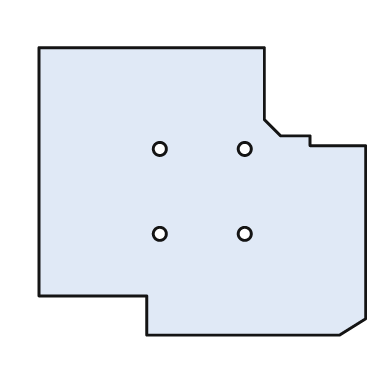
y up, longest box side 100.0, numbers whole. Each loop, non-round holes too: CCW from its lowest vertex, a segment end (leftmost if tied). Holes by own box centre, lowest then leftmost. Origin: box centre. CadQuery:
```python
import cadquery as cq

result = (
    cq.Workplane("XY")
    .moveTo(-17.0, -44.0)
    .lineTo(42.0, -44.0)
    .lineTo(50.0, -39.0)
    .lineTo(50.0, 14.0)
    .lineTo(33.0, 14.0)
    .lineTo(33.0, 17.0)
    .lineTo(24.0, 17.0)
    .lineTo(19.0, 22.0)
    .lineTo(19.0, 44.0)
    .lineTo(-50.0, 44.0)
    .lineTo(-50.0, -32.0)
    .lineTo(-17.0, -32.0)
    .close()
    .moveTo(-13.0, -13.0)
    .circle(2.0)
    .moveTo(13.0, -13.0)
    .circle(2.0)
    .moveTo(-13.0, 13.0)
    .circle(2.0)
    .moveTo(13.0, 13.0)
    .circle(2.0)
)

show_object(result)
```